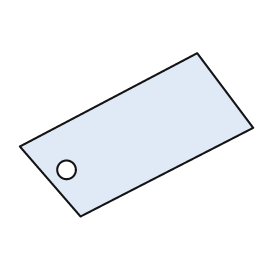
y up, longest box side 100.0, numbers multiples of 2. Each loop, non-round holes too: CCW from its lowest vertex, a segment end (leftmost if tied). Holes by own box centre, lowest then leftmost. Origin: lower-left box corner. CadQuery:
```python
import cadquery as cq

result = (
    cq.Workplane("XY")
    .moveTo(26.0, 0.0)
    .lineTo(100.0, 38.0)
    .lineTo(76.0, 70.0)
    .lineTo(0.0, 30.0)
    .close()
    .moveTo(20.0, 20.0)
    .circle(4.0)
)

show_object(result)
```